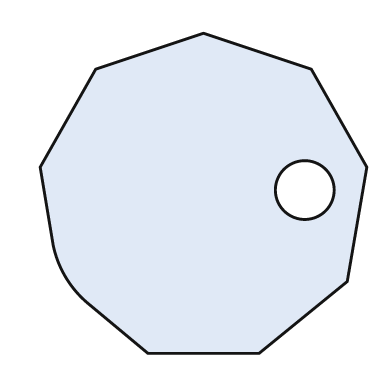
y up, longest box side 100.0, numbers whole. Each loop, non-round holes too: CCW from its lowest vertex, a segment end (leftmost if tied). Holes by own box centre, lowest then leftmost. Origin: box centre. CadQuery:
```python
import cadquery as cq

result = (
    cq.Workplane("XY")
    .moveTo(-17.0, -49.0)
    .lineTo(17.0, -49.0)
    .lineTo(44.0, -27.0)
    .lineTo(50.0, 8.0)
    .lineTo(33.0, 38.0)
    .lineTo(0.0, 49.0)
    .lineTo(-33.0, 38.0)
    .lineTo(-50.0, 8.0)
    .lineTo(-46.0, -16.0)
    .threePointArc((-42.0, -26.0), (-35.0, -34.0))
    .close()
    .moveTo(31.0, 1.0)
    .circle(9.0)
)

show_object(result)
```